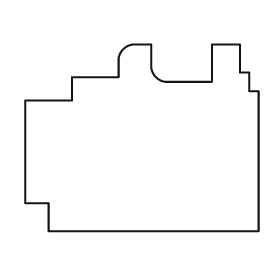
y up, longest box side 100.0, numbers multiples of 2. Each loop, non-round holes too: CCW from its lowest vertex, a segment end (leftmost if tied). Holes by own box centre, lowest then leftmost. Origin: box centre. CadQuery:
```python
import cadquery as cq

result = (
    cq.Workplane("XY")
    .moveTo(-40.0, -40.0)
    .lineTo(50.0, -40.0)
    .lineTo(50.0, 20.0)
    .lineTo(46.0, 20.0)
    .lineTo(46.0, 28.0)
    .lineTo(42.0, 28.0)
    .lineTo(42.0, 40.0)
    .lineTo(30.0, 40.0)
    .lineTo(30.0, 24.0)
    .lineTo(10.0, 24.0)
    .threePointArc((6.0, 26.0), (4.0, 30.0))
    .lineTo(4.0, 40.0)
    .lineTo(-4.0, 40.0)
    .threePointArc((-8.0, 38.0), (-10.0, 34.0))
    .lineTo(-10.0, 26.0)
    .lineTo(-30.0, 26.0)
    .lineTo(-30.0, 16.0)
    .lineTo(-50.0, 16.0)
    .lineTo(-50.0, -28.0)
    .lineTo(-40.0, -28.0)
    .close()
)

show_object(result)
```